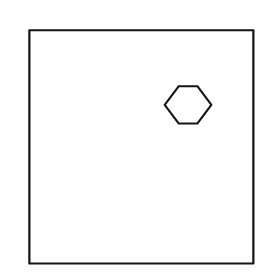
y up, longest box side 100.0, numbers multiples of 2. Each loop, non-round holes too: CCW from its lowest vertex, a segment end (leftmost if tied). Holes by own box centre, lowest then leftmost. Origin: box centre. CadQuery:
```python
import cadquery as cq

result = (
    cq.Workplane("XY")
    .moveTo(-48.0, -50.0)
    .lineTo(48.0, -50.0)
    .lineTo(48.0, 50.0)
    .lineTo(-48.0, 50.0)
    .close()
    .moveTo(16.0, 10.0)
    .lineTo(24.0, 10.0)
    .lineTo(30.0, 18.0)
    .lineTo(24.0, 26.0)
    .lineTo(16.0, 26.0)
    .lineTo(10.0, 18.0)
    .close()
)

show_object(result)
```